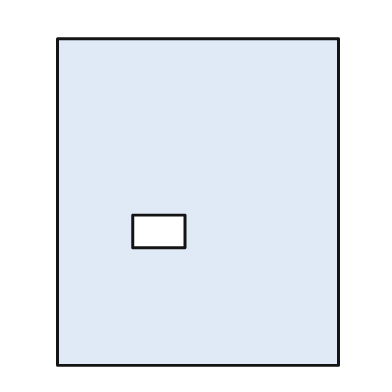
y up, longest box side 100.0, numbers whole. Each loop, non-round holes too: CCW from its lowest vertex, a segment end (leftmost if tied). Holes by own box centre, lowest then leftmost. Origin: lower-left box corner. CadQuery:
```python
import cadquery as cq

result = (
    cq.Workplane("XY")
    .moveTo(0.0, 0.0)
    .lineTo(86.0, 0.0)
    .lineTo(86.0, 100.0)
    .lineTo(0.0, 100.0)
    .close()
    .moveTo(23.0, 36.0)
    .lineTo(39.0, 36.0)
    .lineTo(39.0, 46.0)
    .lineTo(23.0, 46.0)
    .close()
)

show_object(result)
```